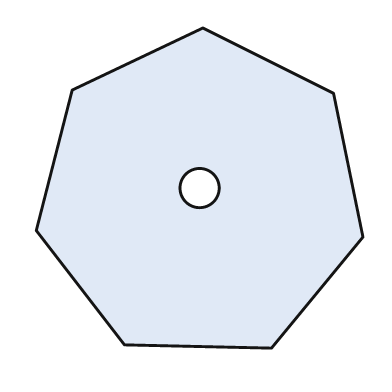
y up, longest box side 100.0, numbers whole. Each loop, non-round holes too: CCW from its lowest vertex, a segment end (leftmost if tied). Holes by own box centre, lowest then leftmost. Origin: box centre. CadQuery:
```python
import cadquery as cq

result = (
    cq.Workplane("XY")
    .moveTo(22.0, -49.0)
    .lineTo(50.0, -15.0)
    .lineTo(41.0, 29.0)
    .lineTo(1.0, 49.0)
    .lineTo(-39.0, 30.0)
    .lineTo(-50.0, -13.0)
    .lineTo(-23.0, -48.0)
    .close()
    .moveTo(0.0, 0.0)
    .circle(6.0)
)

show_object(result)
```